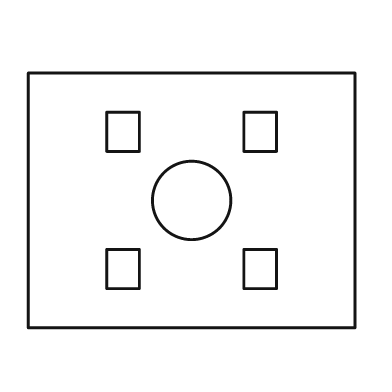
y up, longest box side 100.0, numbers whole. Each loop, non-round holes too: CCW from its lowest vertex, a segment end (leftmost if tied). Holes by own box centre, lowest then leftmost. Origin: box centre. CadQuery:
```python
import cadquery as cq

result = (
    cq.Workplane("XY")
    .moveTo(-50.0, -39.0)
    .lineTo(50.0, -39.0)
    .lineTo(50.0, 39.0)
    .lineTo(-50.0, 39.0)
    .close()
    .moveTo(-26.0, -27.0)
    .lineTo(-16.0, -27.0)
    .lineTo(-16.0, -15.0)
    .lineTo(-26.0, -15.0)
    .close()
    .moveTo(16.0, -27.0)
    .lineTo(26.0, -27.0)
    .lineTo(26.0, -15.0)
    .lineTo(16.0, -15.0)
    .close()
    .moveTo(0.0, 0.0)
    .circle(12.0)
    .moveTo(-26.0, 15.0)
    .lineTo(-16.0, 15.0)
    .lineTo(-16.0, 27.0)
    .lineTo(-26.0, 27.0)
    .close()
    .moveTo(16.0, 15.0)
    .lineTo(26.0, 15.0)
    .lineTo(26.0, 27.0)
    .lineTo(16.0, 27.0)
    .close()
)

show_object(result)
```